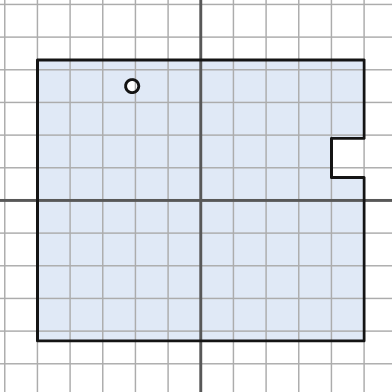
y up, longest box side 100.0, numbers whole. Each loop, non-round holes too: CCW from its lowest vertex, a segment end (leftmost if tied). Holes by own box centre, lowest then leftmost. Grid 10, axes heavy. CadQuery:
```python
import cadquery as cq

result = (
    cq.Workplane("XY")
    .moveTo(-50.0, -43.0)
    .lineTo(50.0, -43.0)
    .lineTo(50.0, 7.0)
    .lineTo(40.0, 7.0)
    .lineTo(40.0, 19.0)
    .lineTo(50.0, 19.0)
    .lineTo(50.0, 43.0)
    .lineTo(-50.0, 43.0)
    .close()
    .moveTo(-21.0, 35.0)
    .circle(2.0)
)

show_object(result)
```